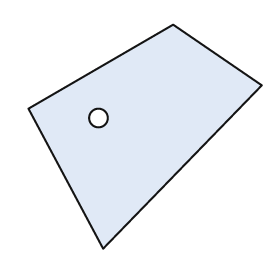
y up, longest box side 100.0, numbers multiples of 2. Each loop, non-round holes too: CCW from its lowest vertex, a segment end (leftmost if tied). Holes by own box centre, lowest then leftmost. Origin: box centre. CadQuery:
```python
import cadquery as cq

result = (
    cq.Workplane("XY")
    .moveTo(-18.0, -48.0)
    .lineTo(50.0, 22.0)
    .lineTo(12.0, 48.0)
    .lineTo(-50.0, 12.0)
    .close()
    .moveTo(-20.0, 8.0)
    .circle(4.0)
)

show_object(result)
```